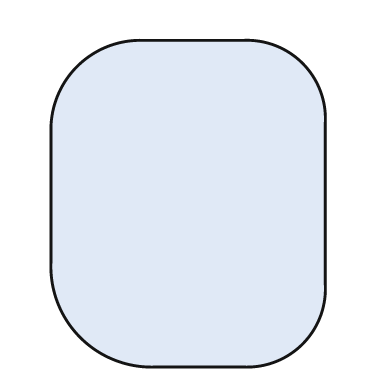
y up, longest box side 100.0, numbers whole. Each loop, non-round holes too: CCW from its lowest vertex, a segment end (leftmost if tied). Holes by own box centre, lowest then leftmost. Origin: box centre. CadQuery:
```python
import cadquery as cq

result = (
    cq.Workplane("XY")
    .moveTo(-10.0, -50.0)
    .lineTo(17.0, -50.0)
    .threePointArc((35.0, -43.0), (42.0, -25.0))
    .lineTo(42.0, 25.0)
    .threePointArc((35.0, 43.0), (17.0, 50.0))
    .lineTo(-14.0, 50.0)
    .threePointArc((-34.0, 42.0), (-42.0, 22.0))
    .lineTo(-42.0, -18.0)
    .threePointArc((-33.0, -41.0), (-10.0, -50.0))
    .close()
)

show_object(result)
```